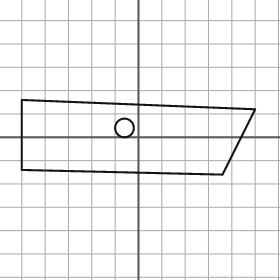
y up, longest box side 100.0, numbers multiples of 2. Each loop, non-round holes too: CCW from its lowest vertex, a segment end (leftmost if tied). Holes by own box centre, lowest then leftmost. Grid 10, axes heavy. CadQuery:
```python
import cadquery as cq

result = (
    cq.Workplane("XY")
    .moveTo(36.0, -16.0)
    .lineTo(50.0, 12.0)
    .lineTo(-50.0, 16.0)
    .lineTo(-50.0, -14.0)
    .close()
    .moveTo(-6.0, 4.0)
    .circle(4.0)
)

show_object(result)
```